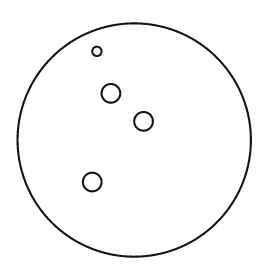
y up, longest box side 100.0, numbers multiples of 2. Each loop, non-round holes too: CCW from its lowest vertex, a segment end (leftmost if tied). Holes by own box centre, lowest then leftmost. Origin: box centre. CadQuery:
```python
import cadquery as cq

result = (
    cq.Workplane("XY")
    .moveTo(0.0, 0.0)
    .circle(50.0)
    .moveTo(-18.0, -18.0)
    .circle(4.0)
    .moveTo(4.0, 8.0)
    .circle(4.0)
    .moveTo(-10.0, 20.0)
    .circle(4.0)
    .moveTo(-16.0, 38.0)
    .circle(2.0)
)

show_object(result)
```